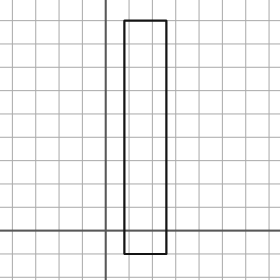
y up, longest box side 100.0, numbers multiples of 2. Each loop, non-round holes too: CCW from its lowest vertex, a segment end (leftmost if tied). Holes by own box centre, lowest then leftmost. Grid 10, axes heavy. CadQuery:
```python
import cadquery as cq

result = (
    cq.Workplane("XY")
    .moveTo(8.0, -10.0)
    .lineTo(26.0, -10.0)
    .lineTo(26.0, 90.0)
    .lineTo(8.0, 90.0)
    .close()
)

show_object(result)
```